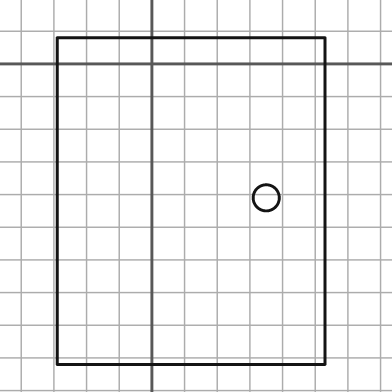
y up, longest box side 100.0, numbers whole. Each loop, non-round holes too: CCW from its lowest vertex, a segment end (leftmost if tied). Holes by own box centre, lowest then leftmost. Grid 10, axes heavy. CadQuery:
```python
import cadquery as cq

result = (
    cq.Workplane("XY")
    .moveTo(-29.0, -92.0)
    .lineTo(53.0, -92.0)
    .lineTo(53.0, 8.0)
    .lineTo(-29.0, 8.0)
    .close()
    .moveTo(35.0, -41.0)
    .circle(4.0)
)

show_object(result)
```